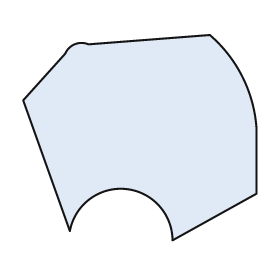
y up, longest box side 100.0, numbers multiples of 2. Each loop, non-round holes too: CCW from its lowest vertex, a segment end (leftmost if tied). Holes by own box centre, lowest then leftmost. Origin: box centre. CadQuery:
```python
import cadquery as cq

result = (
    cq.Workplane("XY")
    .moveTo(14.0, -44.0)
    .lineTo(50.0, -24.0)
    .lineTo(50.0, 4.0)
    .threePointArc((44.0, 26.0), (30.0, 44.0))
    .lineTo(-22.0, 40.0)
    .threePointArc((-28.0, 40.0), (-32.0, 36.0))
    .lineTo(-50.0, 16.0)
    .lineTo(-30.0, -40.0)
    .threePointArc((-6.0, -22.0), (14.0, -44.0))
    .close()
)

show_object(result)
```